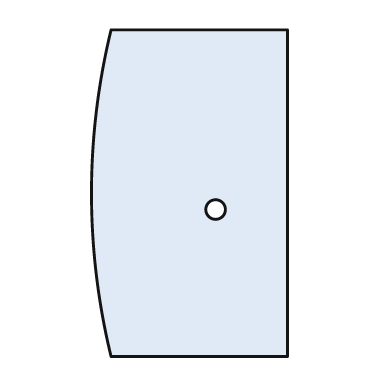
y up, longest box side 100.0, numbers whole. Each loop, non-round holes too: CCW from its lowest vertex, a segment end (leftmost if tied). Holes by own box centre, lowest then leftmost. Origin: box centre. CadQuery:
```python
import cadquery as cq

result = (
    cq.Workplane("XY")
    .moveTo(-24.0, -50.0)
    .lineTo(30.0, -50.0)
    .lineTo(30.0, 50.0)
    .lineTo(-24.0, 50.0)
    .threePointArc((-30.0, 0.0), (-24.0, -50.0))
    .close()
    .moveTo(8.0, -5.0)
    .circle(3.0)
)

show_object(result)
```